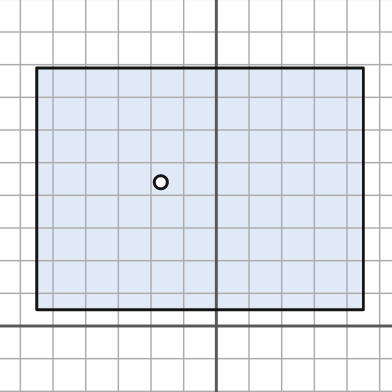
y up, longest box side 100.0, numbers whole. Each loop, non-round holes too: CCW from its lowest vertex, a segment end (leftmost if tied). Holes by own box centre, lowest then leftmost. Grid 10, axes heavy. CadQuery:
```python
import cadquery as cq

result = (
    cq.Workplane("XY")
    .moveTo(-55.0, 5.0)
    .lineTo(45.0, 5.0)
    .lineTo(45.0, 79.0)
    .lineTo(-55.0, 79.0)
    .close()
    .moveTo(-17.0, 44.0)
    .circle(2.0)
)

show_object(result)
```